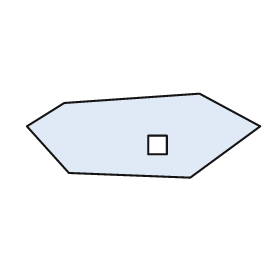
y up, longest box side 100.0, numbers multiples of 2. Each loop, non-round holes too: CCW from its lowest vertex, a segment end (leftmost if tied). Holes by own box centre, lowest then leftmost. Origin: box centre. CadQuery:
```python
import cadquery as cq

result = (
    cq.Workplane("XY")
    .moveTo(20.0, -18.0)
    .lineTo(50.0, 4.0)
    .lineTo(24.0, 18.0)
    .lineTo(-34.0, 14.0)
    .lineTo(-50.0, 4.0)
    .lineTo(-32.0, -16.0)
    .close()
    .moveTo(2.0, -8.0)
    .lineTo(10.0, -8.0)
    .lineTo(10.0, 0.0)
    .lineTo(2.0, 0.0)
    .close()
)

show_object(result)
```